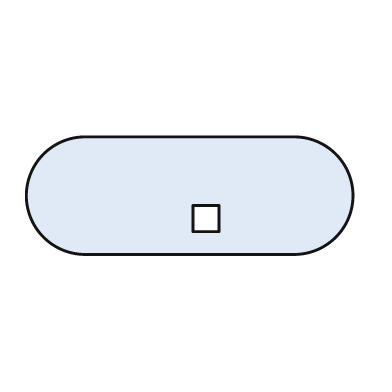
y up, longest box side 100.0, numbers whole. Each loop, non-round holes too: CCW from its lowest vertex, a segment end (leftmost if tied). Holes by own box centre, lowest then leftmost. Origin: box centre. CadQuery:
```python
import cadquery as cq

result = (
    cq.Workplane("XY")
    .moveTo(-32.0, -18.0)
    .lineTo(32.0, -18.0)
    .threePointArc((50.0, 0.0), (32.0, 18.0))
    .lineTo(-32.0, 18.0)
    .threePointArc((-50.0, 0.0), (-32.0, -18.0))
    .close()
    .moveTo(1.0, -11.0)
    .lineTo(9.0, -11.0)
    .lineTo(9.0, -3.0)
    .lineTo(1.0, -3.0)
    .close()
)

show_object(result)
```